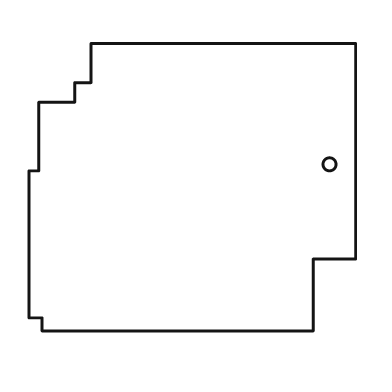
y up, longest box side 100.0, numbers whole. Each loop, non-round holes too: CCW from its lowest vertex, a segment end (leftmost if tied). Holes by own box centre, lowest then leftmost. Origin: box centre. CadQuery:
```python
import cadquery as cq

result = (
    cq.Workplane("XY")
    .moveTo(-46.0, -44.0)
    .lineTo(37.0, -44.0)
    .lineTo(37.0, -22.0)
    .lineTo(50.0, -22.0)
    .lineTo(50.0, 44.0)
    .lineTo(-31.0, 44.0)
    .lineTo(-31.0, 32.0)
    .lineTo(-36.0, 32.0)
    .lineTo(-36.0, 26.0)
    .lineTo(-47.0, 26.0)
    .lineTo(-47.0, 5.0)
    .lineTo(-50.0, 5.0)
    .lineTo(-50.0, -40.0)
    .lineTo(-46.0, -40.0)
    .close()
    .moveTo(42.0, 7.0)
    .circle(2.0)
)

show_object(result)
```